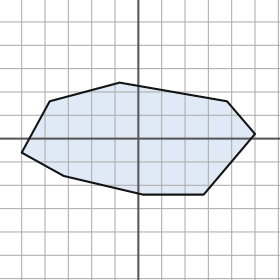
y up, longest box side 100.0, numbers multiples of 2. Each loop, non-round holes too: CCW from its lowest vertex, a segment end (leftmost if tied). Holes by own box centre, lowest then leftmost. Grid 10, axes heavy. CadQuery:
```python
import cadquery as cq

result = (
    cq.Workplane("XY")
    .moveTo(2.0, -24.0)
    .lineTo(28.0, -24.0)
    .lineTo(50.0, 2.0)
    .lineTo(38.0, 16.0)
    .lineTo(-8.0, 24.0)
    .lineTo(-38.0, 16.0)
    .lineTo(-50.0, -6.0)
    .lineTo(-32.0, -16.0)
    .close()
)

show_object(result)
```